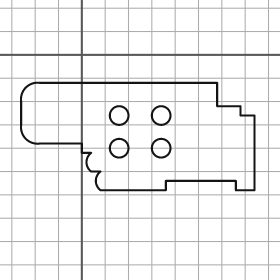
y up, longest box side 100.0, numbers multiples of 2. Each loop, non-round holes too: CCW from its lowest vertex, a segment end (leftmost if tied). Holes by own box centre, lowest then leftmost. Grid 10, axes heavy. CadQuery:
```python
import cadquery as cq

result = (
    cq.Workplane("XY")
    .moveTo(8.0, -58.0)
    .lineTo(36.0, -58.0)
    .lineTo(36.0, -54.0)
    .lineTo(66.0, -54.0)
    .lineTo(66.0, -58.0)
    .lineTo(74.0, -58.0)
    .lineTo(74.0, -26.0)
    .lineTo(68.0, -26.0)
    .lineTo(68.0, -22.0)
    .lineTo(58.0, -22.0)
    .lineTo(58.0, -12.0)
    .lineTo(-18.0, -12.0)
    .threePointArc((-24.0, -14.0), (-26.0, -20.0))
    .lineTo(-26.0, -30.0)
    .threePointArc((-24.0, -36.0), (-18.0, -38.0))
    .lineTo(0.0, -38.0)
    .lineTo(0.0, -42.0)
    .lineTo(4.0, -42.0)
    .threePointArc((2.0, -46.0), (4.0, -50.0))
    .lineTo(8.0, -50.0)
    .threePointArc((6.0, -54.0), (8.0, -58.0))
    .close()
    .moveTo(16.0, -40.0)
    .circle(4.0)
    .moveTo(34.0, -40.0)
    .circle(4.0)
    .moveTo(16.0, -26.0)
    .circle(4.0)
    .moveTo(34.0, -26.0)
    .circle(4.0)
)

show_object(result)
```